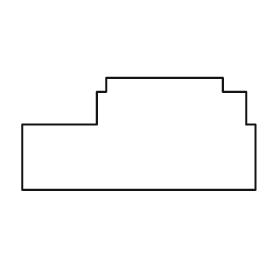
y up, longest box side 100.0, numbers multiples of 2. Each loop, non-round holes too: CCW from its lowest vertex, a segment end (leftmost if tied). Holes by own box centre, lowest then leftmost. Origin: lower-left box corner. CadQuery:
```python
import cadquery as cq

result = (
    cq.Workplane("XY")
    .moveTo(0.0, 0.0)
    .lineTo(100.0, 0.0)
    .lineTo(100.0, 28.0)
    .lineTo(96.0, 28.0)
    .lineTo(96.0, 42.0)
    .lineTo(86.0, 42.0)
    .lineTo(86.0, 48.0)
    .lineTo(36.0, 48.0)
    .lineTo(36.0, 42.0)
    .lineTo(32.0, 42.0)
    .lineTo(32.0, 28.0)
    .lineTo(0.0, 28.0)
    .close()
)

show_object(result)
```